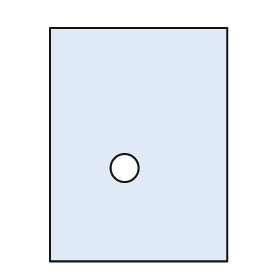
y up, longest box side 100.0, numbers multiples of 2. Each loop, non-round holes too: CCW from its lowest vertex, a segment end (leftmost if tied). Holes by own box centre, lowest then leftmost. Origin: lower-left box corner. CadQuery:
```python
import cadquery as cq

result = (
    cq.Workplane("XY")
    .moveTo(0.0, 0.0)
    .lineTo(76.0, 0.0)
    .lineTo(76.0, 100.0)
    .lineTo(0.0, 100.0)
    .close()
    .moveTo(32.0, 40.0)
    .circle(6.0)
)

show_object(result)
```